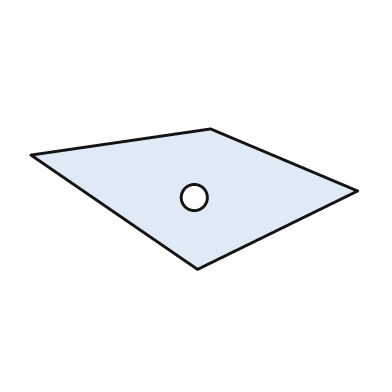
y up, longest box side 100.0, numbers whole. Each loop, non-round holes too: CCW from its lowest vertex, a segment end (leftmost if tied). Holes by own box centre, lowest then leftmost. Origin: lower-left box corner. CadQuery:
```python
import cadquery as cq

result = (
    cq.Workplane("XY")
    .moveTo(51.0, 0.0)
    .lineTo(100.0, 24.0)
    .lineTo(55.0, 43.0)
    .lineTo(0.0, 35.0)
    .close()
    .moveTo(50.0, 22.0)
    .circle(4.0)
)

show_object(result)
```